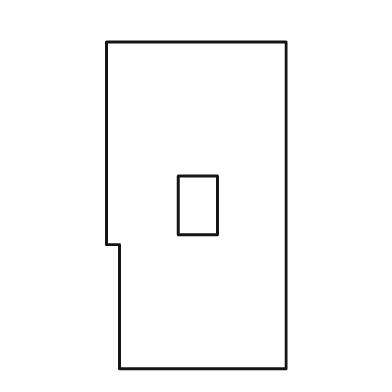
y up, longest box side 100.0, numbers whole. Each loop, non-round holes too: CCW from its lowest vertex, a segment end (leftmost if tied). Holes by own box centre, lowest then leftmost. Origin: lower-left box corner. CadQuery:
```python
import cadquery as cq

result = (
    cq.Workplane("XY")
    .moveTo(4.0, 0.0)
    .lineTo(55.0, 0.0)
    .lineTo(55.0, 100.0)
    .lineTo(0.0, 100.0)
    .lineTo(0.0, 38.0)
    .lineTo(4.0, 38.0)
    .close()
    .moveTo(22.0, 41.0)
    .lineTo(34.0, 41.0)
    .lineTo(34.0, 59.0)
    .lineTo(22.0, 59.0)
    .close()
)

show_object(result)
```